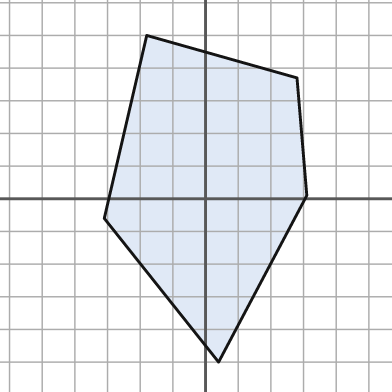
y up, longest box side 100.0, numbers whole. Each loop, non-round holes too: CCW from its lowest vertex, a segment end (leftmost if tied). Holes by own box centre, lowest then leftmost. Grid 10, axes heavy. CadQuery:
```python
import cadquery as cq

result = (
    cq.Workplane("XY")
    .moveTo(4.0, -50.0)
    .lineTo(31.0, 1.0)
    .lineTo(28.0, 37.0)
    .lineTo(-18.0, 50.0)
    .lineTo(-31.0, -6.0)
    .close()
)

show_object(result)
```